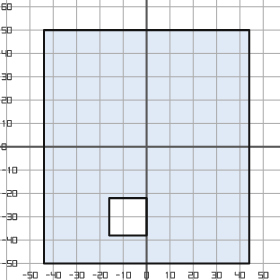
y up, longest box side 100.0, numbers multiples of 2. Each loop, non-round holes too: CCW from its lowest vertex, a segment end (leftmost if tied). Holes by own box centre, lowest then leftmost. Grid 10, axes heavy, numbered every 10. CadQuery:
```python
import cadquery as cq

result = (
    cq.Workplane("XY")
    .moveTo(-44.0, -50.0)
    .lineTo(44.0, -50.0)
    .lineTo(44.0, 50.0)
    .lineTo(-44.0, 50.0)
    .close()
    .moveTo(-16.0, -38.0)
    .lineTo(0.0, -38.0)
    .lineTo(0.0, -22.0)
    .lineTo(-16.0, -22.0)
    .close()
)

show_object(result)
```